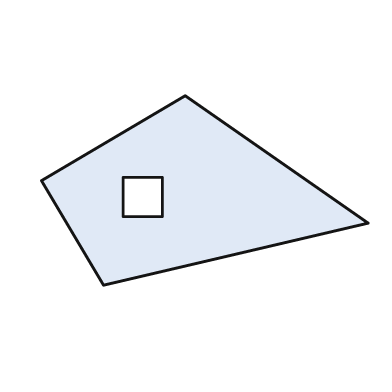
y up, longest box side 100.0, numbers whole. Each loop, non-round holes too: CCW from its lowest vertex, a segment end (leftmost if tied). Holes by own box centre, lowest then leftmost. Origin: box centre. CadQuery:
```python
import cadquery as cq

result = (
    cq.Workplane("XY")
    .moveTo(-31.0, -29.0)
    .lineTo(50.0, -10.0)
    .lineTo(-6.0, 29.0)
    .lineTo(-50.0, 3.0)
    .close()
    .moveTo(-25.0, -8.0)
    .lineTo(-13.0, -8.0)
    .lineTo(-13.0, 4.0)
    .lineTo(-25.0, 4.0)
    .close()
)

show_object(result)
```